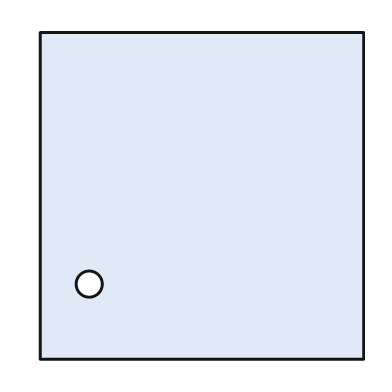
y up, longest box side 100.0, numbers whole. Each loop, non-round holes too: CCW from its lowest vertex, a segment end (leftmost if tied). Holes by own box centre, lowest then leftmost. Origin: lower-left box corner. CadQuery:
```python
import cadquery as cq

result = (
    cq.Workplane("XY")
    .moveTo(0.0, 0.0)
    .lineTo(99.0, 0.0)
    .lineTo(99.0, 100.0)
    .lineTo(0.0, 100.0)
    .close()
    .moveTo(15.0, 23.0)
    .circle(4.0)
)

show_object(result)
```